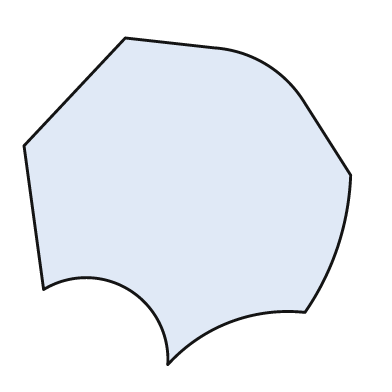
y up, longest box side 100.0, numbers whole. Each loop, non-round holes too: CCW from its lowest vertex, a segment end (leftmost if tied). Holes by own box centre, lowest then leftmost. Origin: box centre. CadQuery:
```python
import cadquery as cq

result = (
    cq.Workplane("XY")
    .moveTo(-6.0, -50.0)
    .threePointArc((13.0, -37.0), (36.0, -34.0))
    .threePointArc((46.0, -14.0), (50.0, 8.0))
    .lineTo(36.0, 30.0)
    .threePointArc((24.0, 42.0), (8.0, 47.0))
    .lineTo(-19.0, 50.0)
    .lineTo(-50.0, 17.0)
    .lineTo(-44.0, -27.0)
    .threePointArc((-18.0, -27.0), (-6.0, -50.0))
    .close()
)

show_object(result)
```